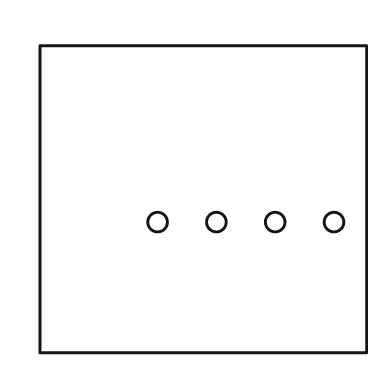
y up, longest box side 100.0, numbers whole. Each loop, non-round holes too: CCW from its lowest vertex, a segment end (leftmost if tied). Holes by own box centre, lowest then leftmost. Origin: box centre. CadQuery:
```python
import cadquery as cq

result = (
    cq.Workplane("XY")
    .moveTo(-50.0, -47.0)
    .lineTo(50.0, -47.0)
    .lineTo(50.0, 47.0)
    .lineTo(-50.0, 47.0)
    .close()
    .moveTo(-14.0, -7.0)
    .circle(3.0)
    .moveTo(4.0, -7.0)
    .circle(3.0)
    .moveTo(22.0, -7.0)
    .circle(3.0)
    .moveTo(40.0, -7.0)
    .circle(3.0)
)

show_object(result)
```